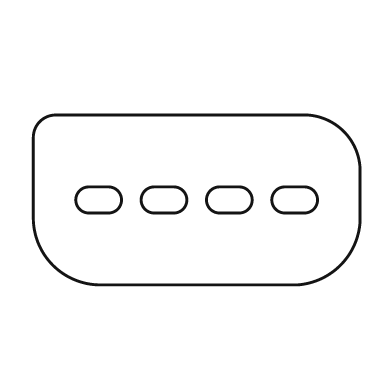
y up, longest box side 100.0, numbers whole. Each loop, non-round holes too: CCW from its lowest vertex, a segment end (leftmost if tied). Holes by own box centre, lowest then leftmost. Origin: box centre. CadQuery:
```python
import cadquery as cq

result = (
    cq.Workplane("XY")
    .moveTo(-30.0, -26.0)
    .lineTo(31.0, -26.0)
    .threePointArc((44.0, -20.0), (50.0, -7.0))
    .lineTo(50.0, 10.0)
    .threePointArc((45.0, 21.0), (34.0, 26.0))
    .lineTo(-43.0, 26.0)
    .threePointArc((-48.0, 24.0), (-50.0, 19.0))
    .lineTo(-50.0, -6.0)
    .threePointArc((-44.0, -20.0), (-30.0, -26.0))
    .close()
    .moveTo(-33.0, -4.0)
    .lineTo(-27.0, -4.0)
    .threePointArc((-23.0, 0.0), (-27.0, 4.0))
    .lineTo(-33.0, 4.0)
    .threePointArc((-37.0, 0.0), (-33.0, -4.0))
    .close()
    .moveTo(-13.0, -4.0)
    .lineTo(-7.0, -4.0)
    .threePointArc((-3.0, 0.0), (-7.0, 4.0))
    .lineTo(-13.0, 4.0)
    .threePointArc((-17.0, 0.0), (-13.0, -4.0))
    .close()
    .moveTo(7.0, -4.0)
    .lineTo(13.0, -4.0)
    .threePointArc((17.0, 0.0), (13.0, 4.0))
    .lineTo(7.0, 4.0)
    .threePointArc((3.0, 0.0), (7.0, -4.0))
    .close()
    .moveTo(27.0, -4.0)
    .lineTo(33.0, -4.0)
    .threePointArc((37.0, 0.0), (33.0, 4.0))
    .lineTo(27.0, 4.0)
    .threePointArc((23.0, 0.0), (27.0, -4.0))
    .close()
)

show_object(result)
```